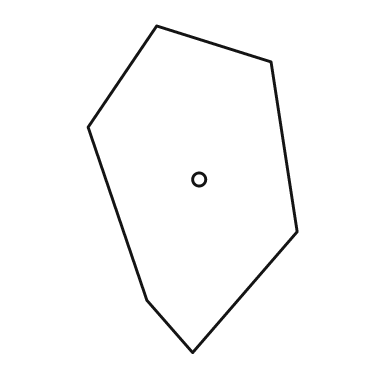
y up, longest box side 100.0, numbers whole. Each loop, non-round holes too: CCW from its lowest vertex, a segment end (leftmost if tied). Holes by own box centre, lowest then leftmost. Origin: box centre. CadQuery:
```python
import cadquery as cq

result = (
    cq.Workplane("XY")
    .moveTo(0.0, -50.0)
    .lineTo(32.0, -13.0)
    .lineTo(24.0, 39.0)
    .lineTo(-11.0, 50.0)
    .lineTo(-32.0, 19.0)
    .lineTo(-14.0, -34.0)
    .close()
    .moveTo(2.0, 3.0)
    .circle(2.0)
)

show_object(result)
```